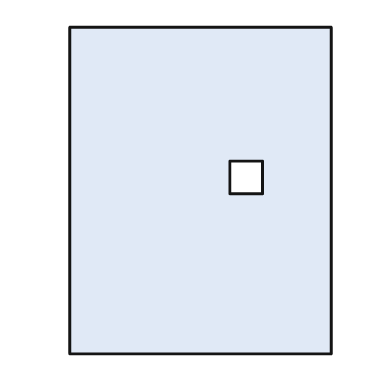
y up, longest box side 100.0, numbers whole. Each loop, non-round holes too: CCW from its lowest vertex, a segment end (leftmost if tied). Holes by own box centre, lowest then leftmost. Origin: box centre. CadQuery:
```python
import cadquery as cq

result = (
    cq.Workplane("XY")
    .moveTo(-40.0, -50.0)
    .lineTo(40.0, -50.0)
    .lineTo(40.0, 50.0)
    .lineTo(-40.0, 50.0)
    .close()
    .moveTo(9.0, -1.0)
    .lineTo(19.0, -1.0)
    .lineTo(19.0, 9.0)
    .lineTo(9.0, 9.0)
    .close()
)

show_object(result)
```